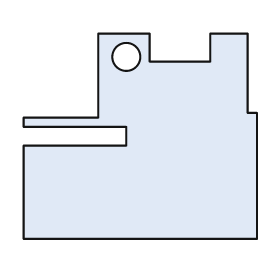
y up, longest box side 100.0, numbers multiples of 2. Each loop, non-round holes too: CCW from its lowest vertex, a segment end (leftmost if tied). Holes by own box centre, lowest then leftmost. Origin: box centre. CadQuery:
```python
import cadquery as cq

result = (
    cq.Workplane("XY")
    .moveTo(-50.0, -44.0)
    .lineTo(50.0, -44.0)
    .lineTo(50.0, 10.0)
    .lineTo(46.0, 10.0)
    .lineTo(46.0, 44.0)
    .lineTo(30.0, 44.0)
    .lineTo(30.0, 32.0)
    .lineTo(4.0, 32.0)
    .lineTo(4.0, 44.0)
    .lineTo(-18.0, 44.0)
    .lineTo(-18.0, 8.0)
    .lineTo(-50.0, 8.0)
    .lineTo(-50.0, 4.0)
    .lineTo(-6.0, 4.0)
    .lineTo(-6.0, -4.0)
    .lineTo(-50.0, -4.0)
    .close()
    .moveTo(-6.0, 34.0)
    .circle(6.0)
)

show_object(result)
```